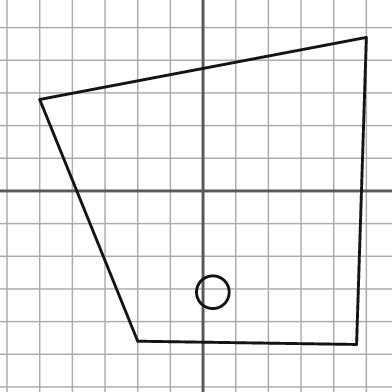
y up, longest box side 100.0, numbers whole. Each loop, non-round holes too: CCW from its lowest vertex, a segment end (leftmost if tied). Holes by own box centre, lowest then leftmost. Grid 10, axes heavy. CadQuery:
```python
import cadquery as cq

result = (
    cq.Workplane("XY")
    .moveTo(47.0, -47.0)
    .lineTo(50.0, 47.0)
    .lineTo(-50.0, 28.0)
    .lineTo(-20.0, -46.0)
    .close()
    .moveTo(3.0, -31.0)
    .circle(5.0)
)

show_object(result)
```